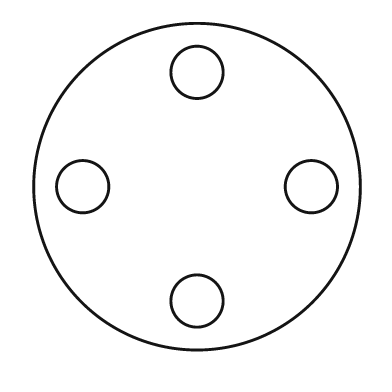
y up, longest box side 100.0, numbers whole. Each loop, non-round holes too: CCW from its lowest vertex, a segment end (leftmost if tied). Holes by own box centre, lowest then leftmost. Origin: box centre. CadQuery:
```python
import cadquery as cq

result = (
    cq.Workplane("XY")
    .moveTo(0.0, 0.0)
    .circle(50.0)
    .moveTo(0.0, -35.0)
    .circle(8.0)
    .moveTo(-35.0, 0.0)
    .circle(8.0)
    .moveTo(35.0, 0.0)
    .circle(8.0)
    .moveTo(0.0, 35.0)
    .circle(8.0)
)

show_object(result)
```